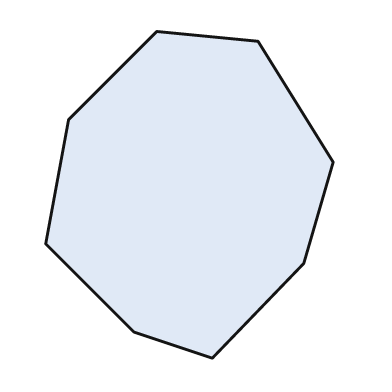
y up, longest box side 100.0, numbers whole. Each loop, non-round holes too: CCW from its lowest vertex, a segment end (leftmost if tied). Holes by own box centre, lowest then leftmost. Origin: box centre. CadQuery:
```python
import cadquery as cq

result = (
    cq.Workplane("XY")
    .moveTo(7.0, -50.0)
    .lineTo(35.0, -21.0)
    .lineTo(44.0, 10.0)
    .lineTo(21.0, 47.0)
    .lineTo(-10.0, 50.0)
    .lineTo(-37.0, 23.0)
    .lineTo(-44.0, -15.0)
    .lineTo(-17.0, -42.0)
    .close()
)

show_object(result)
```